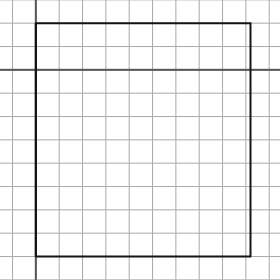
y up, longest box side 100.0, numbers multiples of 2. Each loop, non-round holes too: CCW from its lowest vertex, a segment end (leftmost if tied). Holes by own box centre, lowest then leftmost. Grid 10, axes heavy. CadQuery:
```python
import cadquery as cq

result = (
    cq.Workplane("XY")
    .moveTo(0.0, -80.0)
    .lineTo(92.0, -80.0)
    .lineTo(92.0, 20.0)
    .lineTo(0.0, 20.0)
    .close()
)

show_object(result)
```